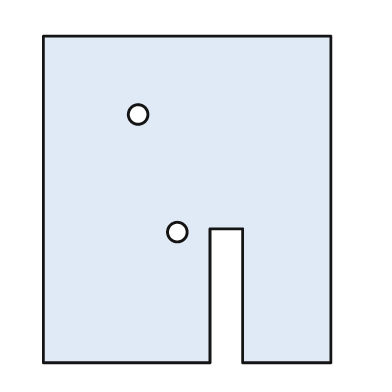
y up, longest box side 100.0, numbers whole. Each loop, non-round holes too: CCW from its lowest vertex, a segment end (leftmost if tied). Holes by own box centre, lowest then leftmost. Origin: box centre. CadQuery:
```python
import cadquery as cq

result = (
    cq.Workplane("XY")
    .moveTo(-44.0, -50.0)
    .lineTo(7.0, -50.0)
    .lineTo(7.0, -9.0)
    .lineTo(17.0, -9.0)
    .lineTo(17.0, -50.0)
    .lineTo(44.0, -50.0)
    .lineTo(44.0, 50.0)
    .lineTo(-44.0, 50.0)
    .close()
    .moveTo(-3.0, -10.0)
    .circle(3.0)
    .moveTo(-15.0, 26.0)
    .circle(3.0)
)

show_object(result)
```